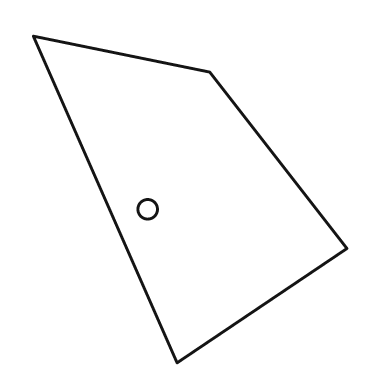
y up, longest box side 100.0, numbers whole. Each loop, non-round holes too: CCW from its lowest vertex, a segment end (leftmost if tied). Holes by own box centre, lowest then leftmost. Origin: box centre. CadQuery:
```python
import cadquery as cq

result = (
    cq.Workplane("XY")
    .moveTo(-4.0, -50.0)
    .lineTo(48.0, -15.0)
    .lineTo(6.0, 39.0)
    .lineTo(-48.0, 50.0)
    .close()
    .moveTo(-13.0, -3.0)
    .circle(3.0)
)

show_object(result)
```